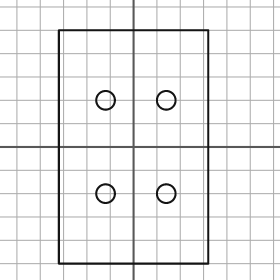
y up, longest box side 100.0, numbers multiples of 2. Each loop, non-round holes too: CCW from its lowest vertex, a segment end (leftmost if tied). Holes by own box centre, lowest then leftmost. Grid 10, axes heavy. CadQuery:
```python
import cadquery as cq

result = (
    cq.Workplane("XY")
    .moveTo(-32.0, -50.0)
    .lineTo(32.0, -50.0)
    .lineTo(32.0, 50.0)
    .lineTo(-32.0, 50.0)
    .close()
    .moveTo(-12.0, -20.0)
    .circle(4.0)
    .moveTo(14.0, -20.0)
    .circle(4.0)
    .moveTo(-12.0, 20.0)
    .circle(4.0)
    .moveTo(14.0, 20.0)
    .circle(4.0)
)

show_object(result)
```